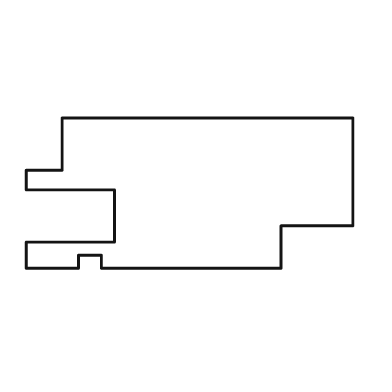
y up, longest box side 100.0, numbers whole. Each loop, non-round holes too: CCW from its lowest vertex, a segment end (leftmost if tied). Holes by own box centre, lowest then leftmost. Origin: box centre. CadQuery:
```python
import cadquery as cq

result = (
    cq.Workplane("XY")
    .moveTo(-50.0, -23.0)
    .lineTo(-34.0, -23.0)
    .lineTo(-34.0, -19.0)
    .lineTo(-27.0, -19.0)
    .lineTo(-27.0, -23.0)
    .lineTo(28.0, -23.0)
    .lineTo(28.0, -10.0)
    .lineTo(50.0, -10.0)
    .lineTo(50.0, 23.0)
    .lineTo(-39.0, 23.0)
    .lineTo(-39.0, 7.0)
    .lineTo(-50.0, 7.0)
    .lineTo(-50.0, 1.0)
    .lineTo(-23.0, 1.0)
    .lineTo(-23.0, -15.0)
    .lineTo(-50.0, -15.0)
    .close()
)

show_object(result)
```